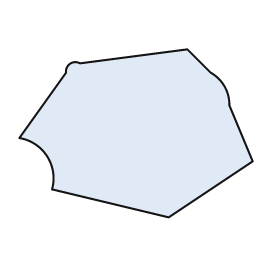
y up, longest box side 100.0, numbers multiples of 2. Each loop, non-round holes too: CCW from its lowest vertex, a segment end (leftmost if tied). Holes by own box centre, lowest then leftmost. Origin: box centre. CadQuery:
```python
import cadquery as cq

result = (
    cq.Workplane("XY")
    .moveTo(14.0, -36.0)
    .lineTo(50.0, -12.0)
    .lineTo(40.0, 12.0)
    .threePointArc((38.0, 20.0), (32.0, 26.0))
    .lineTo(22.0, 36.0)
    .lineTo(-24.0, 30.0)
    .threePointArc((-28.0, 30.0), (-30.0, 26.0))
    .lineTo(-50.0, -2.0)
    .threePointArc((-38.0, -10.0), (-36.0, -24.0))
    .close()
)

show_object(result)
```